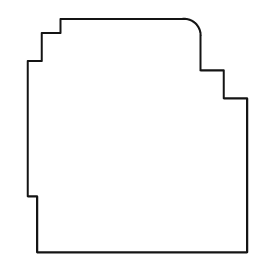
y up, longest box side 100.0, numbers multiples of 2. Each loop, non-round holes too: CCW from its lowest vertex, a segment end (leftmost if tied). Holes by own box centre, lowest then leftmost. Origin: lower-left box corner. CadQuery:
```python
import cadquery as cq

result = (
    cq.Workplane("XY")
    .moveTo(4.0, 0.0)
    .lineTo(94.0, 0.0)
    .lineTo(94.0, 66.0)
    .lineTo(84.0, 66.0)
    .lineTo(84.0, 78.0)
    .lineTo(74.0, 78.0)
    .lineTo(74.0, 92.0)
    .threePointArc((72.0, 98.0), (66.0, 100.0))
    .lineTo(14.0, 100.0)
    .lineTo(14.0, 94.0)
    .lineTo(6.0, 94.0)
    .lineTo(6.0, 82.0)
    .lineTo(0.0, 82.0)
    .lineTo(0.0, 24.0)
    .lineTo(4.0, 24.0)
    .close()
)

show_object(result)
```